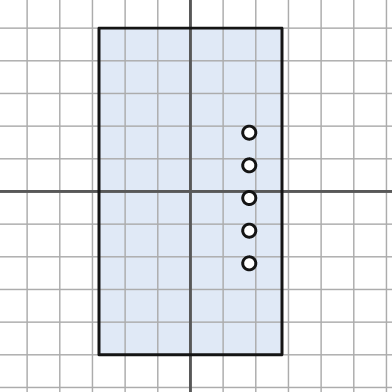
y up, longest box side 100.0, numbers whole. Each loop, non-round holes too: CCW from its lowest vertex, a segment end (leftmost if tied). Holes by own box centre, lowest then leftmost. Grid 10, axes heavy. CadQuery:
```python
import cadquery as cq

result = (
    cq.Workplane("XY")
    .moveTo(-28.0, -50.0)
    .lineTo(28.0, -50.0)
    .lineTo(28.0, 50.0)
    .lineTo(-28.0, 50.0)
    .close()
    .moveTo(18.0, -22.0)
    .circle(2.0)
    .moveTo(18.0, -12.0)
    .circle(2.0)
    .moveTo(18.0, -2.0)
    .circle(2.0)
    .moveTo(18.0, 8.0)
    .circle(2.0)
    .moveTo(18.0, 18.0)
    .circle(2.0)
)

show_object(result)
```